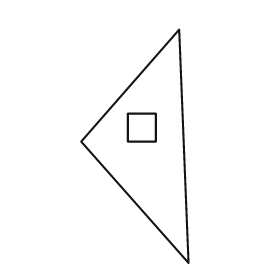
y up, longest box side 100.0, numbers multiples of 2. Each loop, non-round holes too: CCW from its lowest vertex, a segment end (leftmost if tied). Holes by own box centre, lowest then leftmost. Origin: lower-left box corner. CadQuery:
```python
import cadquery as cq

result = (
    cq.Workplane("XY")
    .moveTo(46.0, 0.0)
    .lineTo(42.0, 100.0)
    .lineTo(0.0, 52.0)
    .close()
    .moveTo(20.0, 52.0)
    .lineTo(32.0, 52.0)
    .lineTo(32.0, 64.0)
    .lineTo(20.0, 64.0)
    .close()
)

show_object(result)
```